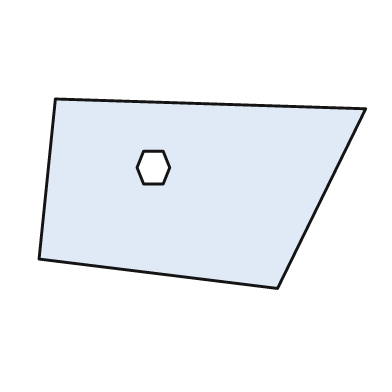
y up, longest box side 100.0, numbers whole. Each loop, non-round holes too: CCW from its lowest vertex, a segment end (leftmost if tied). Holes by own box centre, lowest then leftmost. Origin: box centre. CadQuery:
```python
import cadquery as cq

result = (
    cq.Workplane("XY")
    .moveTo(23.0, -29.0)
    .lineTo(50.0, 26.0)
    .lineTo(-45.0, 29.0)
    .lineTo(-50.0, -20.0)
    .close()
    .moveTo(-18.0, 3.0)
    .lineTo(-12.0, 3.0)
    .lineTo(-10.0, 8.0)
    .lineTo(-12.0, 13.0)
    .lineTo(-18.0, 13.0)
    .lineTo(-20.0, 8.0)
    .close()
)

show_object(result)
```